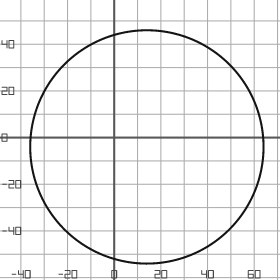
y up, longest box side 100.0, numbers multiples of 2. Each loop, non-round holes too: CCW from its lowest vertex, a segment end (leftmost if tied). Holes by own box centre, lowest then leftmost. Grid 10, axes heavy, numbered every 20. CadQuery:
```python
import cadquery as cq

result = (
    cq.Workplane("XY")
    .moveTo(14.0, -4.0)
    .circle(50.0)
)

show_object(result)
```